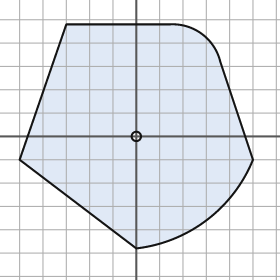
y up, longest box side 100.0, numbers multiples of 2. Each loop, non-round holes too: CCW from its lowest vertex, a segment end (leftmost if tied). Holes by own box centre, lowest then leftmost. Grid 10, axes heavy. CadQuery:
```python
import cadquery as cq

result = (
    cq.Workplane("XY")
    .moveTo(0.0, -48.0)
    .threePointArc((30.0, -36.0), (50.0, -10.0))
    .lineTo(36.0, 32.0)
    .threePointArc((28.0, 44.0), (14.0, 48.0))
    .lineTo(-30.0, 48.0)
    .lineTo(-50.0, -10.0)
    .close()
    .moveTo(0.0, 0.0)
    .circle(2.0)
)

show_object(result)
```